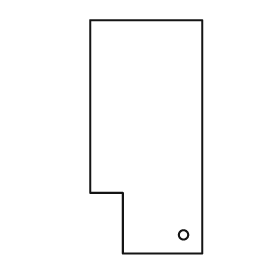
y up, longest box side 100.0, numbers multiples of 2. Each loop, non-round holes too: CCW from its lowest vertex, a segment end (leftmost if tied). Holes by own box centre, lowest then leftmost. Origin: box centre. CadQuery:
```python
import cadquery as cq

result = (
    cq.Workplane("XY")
    .moveTo(-10.0, -50.0)
    .lineTo(24.0, -50.0)
    .lineTo(24.0, 50.0)
    .lineTo(-24.0, 50.0)
    .lineTo(-24.0, -24.0)
    .lineTo(-10.0, -24.0)
    .close()
    .moveTo(16.0, -42.0)
    .circle(2.0)
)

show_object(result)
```